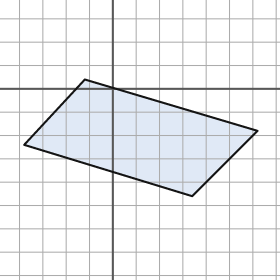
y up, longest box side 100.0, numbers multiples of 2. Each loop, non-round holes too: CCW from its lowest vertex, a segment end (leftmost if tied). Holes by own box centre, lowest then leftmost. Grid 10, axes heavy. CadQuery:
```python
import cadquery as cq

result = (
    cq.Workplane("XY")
    .moveTo(34.0, -46.0)
    .lineTo(62.0, -18.0)
    .lineTo(-12.0, 4.0)
    .lineTo(-38.0, -24.0)
    .close()
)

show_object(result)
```